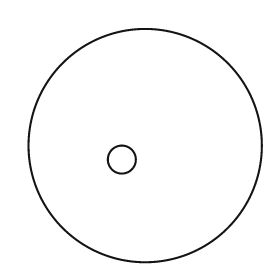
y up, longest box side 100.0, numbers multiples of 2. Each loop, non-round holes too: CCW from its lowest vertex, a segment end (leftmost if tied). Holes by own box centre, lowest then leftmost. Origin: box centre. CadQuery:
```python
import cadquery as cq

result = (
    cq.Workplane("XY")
    .moveTo(0.0, 0.0)
    .circle(50.0)
    .moveTo(-10.0, -6.0)
    .circle(6.0)
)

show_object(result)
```